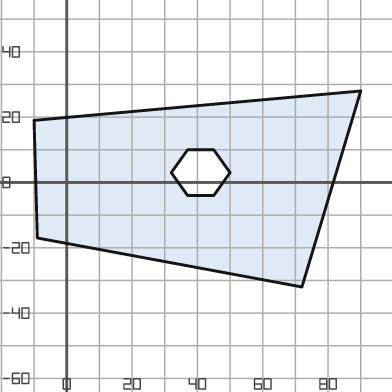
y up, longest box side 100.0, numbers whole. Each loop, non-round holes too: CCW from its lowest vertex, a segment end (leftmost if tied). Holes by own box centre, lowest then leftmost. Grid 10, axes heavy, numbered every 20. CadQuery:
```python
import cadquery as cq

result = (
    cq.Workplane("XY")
    .moveTo(72.0, -32.0)
    .lineTo(90.0, 28.0)
    .lineTo(-10.0, 19.0)
    .lineTo(-9.0, -17.0)
    .close()
    .moveTo(37.0, -4.0)
    .lineTo(45.0, -4.0)
    .lineTo(50.0, 3.0)
    .lineTo(45.0, 10.0)
    .lineTo(37.0, 10.0)
    .lineTo(32.0, 3.0)
    .close()
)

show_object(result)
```